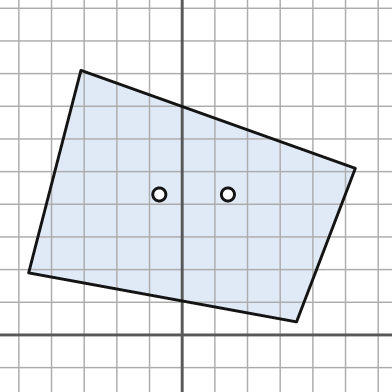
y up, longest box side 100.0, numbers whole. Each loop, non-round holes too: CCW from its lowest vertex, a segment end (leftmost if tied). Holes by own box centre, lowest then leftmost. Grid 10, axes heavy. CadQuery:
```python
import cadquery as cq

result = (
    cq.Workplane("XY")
    .moveTo(35.0, 4.0)
    .lineTo(53.0, 51.0)
    .lineTo(-31.0, 81.0)
    .lineTo(-47.0, 19.0)
    .close()
    .moveTo(-7.0, 43.0)
    .circle(2.0)
    .moveTo(14.0, 43.0)
    .circle(2.0)
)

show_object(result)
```